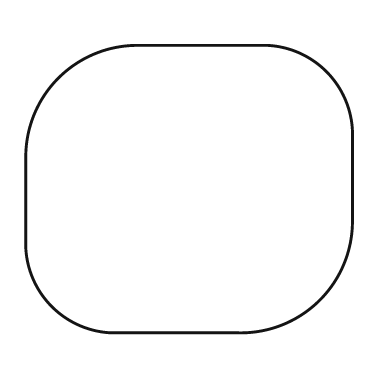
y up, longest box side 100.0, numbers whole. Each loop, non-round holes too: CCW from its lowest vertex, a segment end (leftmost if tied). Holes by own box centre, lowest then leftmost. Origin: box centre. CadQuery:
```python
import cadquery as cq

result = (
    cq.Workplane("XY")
    .moveTo(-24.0, -44.0)
    .lineTo(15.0, -44.0)
    .threePointArc((40.0, -34.0), (50.0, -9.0))
    .lineTo(50.0, 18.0)
    .threePointArc((42.0, 36.0), (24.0, 44.0))
    .lineTo(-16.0, 44.0)
    .threePointArc((-40.0, 34.0), (-50.0, 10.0))
    .lineTo(-50.0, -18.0)
    .threePointArc((-42.0, -36.0), (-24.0, -44.0))
    .close()
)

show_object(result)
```